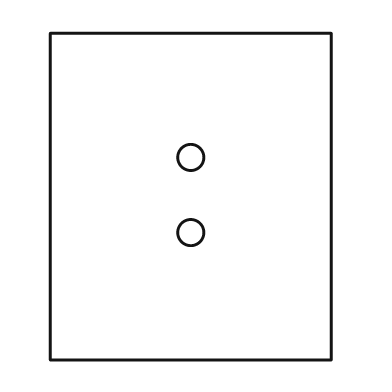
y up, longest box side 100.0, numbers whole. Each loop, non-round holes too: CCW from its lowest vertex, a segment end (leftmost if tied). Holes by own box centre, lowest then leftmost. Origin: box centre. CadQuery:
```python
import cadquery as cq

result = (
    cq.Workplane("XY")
    .moveTo(-43.0, -50.0)
    .lineTo(43.0, -50.0)
    .lineTo(43.0, 50.0)
    .lineTo(-43.0, 50.0)
    .close()
    .moveTo(0.0, -11.0)
    .circle(4.0)
    .moveTo(0.0, 12.0)
    .circle(4.0)
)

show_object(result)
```